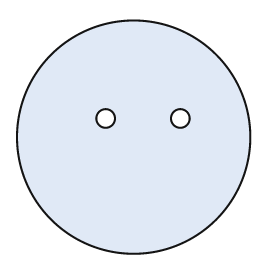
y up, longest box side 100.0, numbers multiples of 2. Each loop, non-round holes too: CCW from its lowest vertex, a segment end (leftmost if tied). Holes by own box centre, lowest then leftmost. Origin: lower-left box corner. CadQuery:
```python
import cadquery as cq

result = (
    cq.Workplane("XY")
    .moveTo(50.0, 50.0)
    .circle(50.0)
    .moveTo(38.0, 58.0)
    .circle(4.0)
    .moveTo(70.0, 58.0)
    .circle(4.0)
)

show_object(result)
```